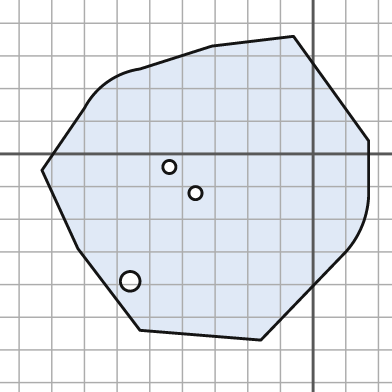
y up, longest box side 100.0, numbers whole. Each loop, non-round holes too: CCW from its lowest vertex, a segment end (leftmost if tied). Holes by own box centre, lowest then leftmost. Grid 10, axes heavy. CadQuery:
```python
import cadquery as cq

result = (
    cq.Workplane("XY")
    .moveTo(-16.0, -57.0)
    .lineTo(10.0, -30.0)
    .threePointArc((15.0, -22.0), (17.0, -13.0))
    .lineTo(17.0, 4.0)
    .lineTo(-6.0, 36.0)
    .lineTo(-31.0, 33.0)
    .lineTo(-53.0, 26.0)
    .threePointArc((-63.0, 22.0), (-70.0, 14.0))
    .lineTo(-83.0, -5.0)
    .lineTo(-72.0, -29.0)
    .lineTo(-53.0, -54.0)
    .close()
    .moveTo(-56.0, -39.0)
    .circle(3.0)
    .moveTo(-36.0, -12.0)
    .circle(2.0)
    .moveTo(-44.0, -4.0)
    .circle(2.0)
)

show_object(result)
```